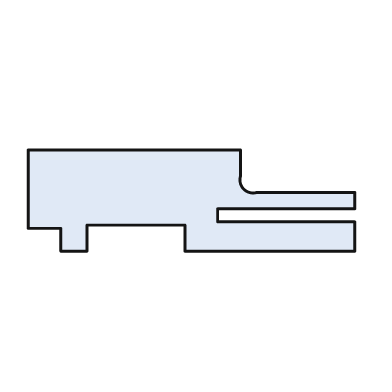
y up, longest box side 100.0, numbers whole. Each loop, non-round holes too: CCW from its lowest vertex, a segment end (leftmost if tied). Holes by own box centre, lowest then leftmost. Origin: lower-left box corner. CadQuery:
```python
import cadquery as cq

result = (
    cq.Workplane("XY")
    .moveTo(10.0, 0.0)
    .lineTo(18.0, 0.0)
    .lineTo(18.0, 8.0)
    .lineTo(48.0, 8.0)
    .lineTo(48.0, 0.0)
    .lineTo(100.0, 0.0)
    .lineTo(100.0, 9.0)
    .lineTo(58.0, 9.0)
    .lineTo(58.0, 13.0)
    .lineTo(100.0, 13.0)
    .lineTo(100.0, 18.0)
    .lineTo(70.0, 18.0)
    .threePointArc((66.0, 19.0), (65.0, 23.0))
    .lineTo(65.0, 31.0)
    .lineTo(0.0, 31.0)
    .lineTo(0.0, 7.0)
    .lineTo(10.0, 7.0)
    .close()
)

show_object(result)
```